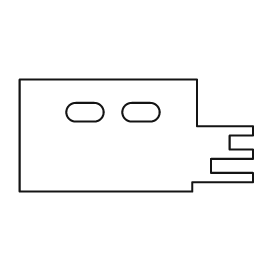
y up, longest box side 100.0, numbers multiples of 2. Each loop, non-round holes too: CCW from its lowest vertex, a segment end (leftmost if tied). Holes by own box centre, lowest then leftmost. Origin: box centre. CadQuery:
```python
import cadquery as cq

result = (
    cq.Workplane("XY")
    .moveTo(-50.0, -24.0)
    .lineTo(24.0, -24.0)
    .lineTo(24.0, -20.0)
    .lineTo(50.0, -20.0)
    .lineTo(50.0, -16.0)
    .lineTo(32.0, -16.0)
    .lineTo(32.0, -10.0)
    .lineTo(50.0, -10.0)
    .lineTo(50.0, -6.0)
    .lineTo(40.0, -6.0)
    .lineTo(40.0, 0.0)
    .lineTo(50.0, 0.0)
    .lineTo(50.0, 4.0)
    .lineTo(26.0, 4.0)
    .lineTo(26.0, 24.0)
    .lineTo(-50.0, 24.0)
    .close()
    .moveTo(-26.0, 6.0)
    .lineTo(-18.0, 6.0)
    .threePointArc((-14.0, 10.0), (-18.0, 14.0))
    .lineTo(-26.0, 14.0)
    .threePointArc((-30.0, 10.0), (-26.0, 6.0))
    .close()
    .moveTo(-2.0, 6.0)
    .lineTo(6.0, 6.0)
    .threePointArc((10.0, 10.0), (6.0, 14.0))
    .lineTo(-2.0, 14.0)
    .threePointArc((-6.0, 10.0), (-2.0, 6.0))
    .close()
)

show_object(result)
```